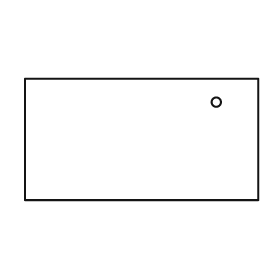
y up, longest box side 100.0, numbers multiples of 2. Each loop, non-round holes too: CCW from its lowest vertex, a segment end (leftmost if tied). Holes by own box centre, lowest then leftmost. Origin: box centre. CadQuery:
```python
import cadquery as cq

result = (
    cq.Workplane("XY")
    .moveTo(-50.0, -26.0)
    .lineTo(50.0, -26.0)
    .lineTo(50.0, 26.0)
    .lineTo(-50.0, 26.0)
    .close()
    .moveTo(32.0, 16.0)
    .circle(2.0)
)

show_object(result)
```